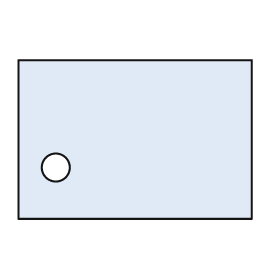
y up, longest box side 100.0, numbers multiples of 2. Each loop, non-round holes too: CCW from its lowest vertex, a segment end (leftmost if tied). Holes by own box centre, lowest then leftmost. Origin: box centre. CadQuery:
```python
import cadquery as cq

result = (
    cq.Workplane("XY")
    .moveTo(-50.0, -34.0)
    .lineTo(50.0, -34.0)
    .lineTo(50.0, 34.0)
    .lineTo(-50.0, 34.0)
    .close()
    .moveTo(-34.0, -12.0)
    .circle(6.0)
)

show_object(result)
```